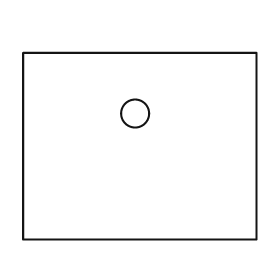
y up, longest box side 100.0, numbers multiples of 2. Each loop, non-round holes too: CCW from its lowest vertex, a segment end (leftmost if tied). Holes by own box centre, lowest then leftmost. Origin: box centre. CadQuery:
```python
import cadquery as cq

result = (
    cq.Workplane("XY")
    .moveTo(-50.0, -40.0)
    .lineTo(50.0, -40.0)
    .lineTo(50.0, 40.0)
    .lineTo(-50.0, 40.0)
    .close()
    .moveTo(-2.0, 14.0)
    .circle(6.0)
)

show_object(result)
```